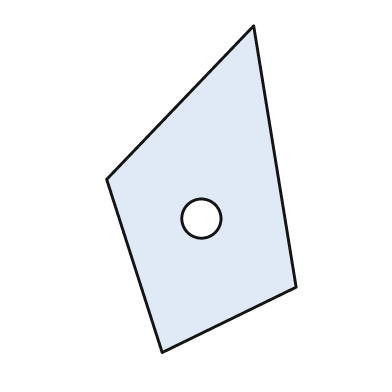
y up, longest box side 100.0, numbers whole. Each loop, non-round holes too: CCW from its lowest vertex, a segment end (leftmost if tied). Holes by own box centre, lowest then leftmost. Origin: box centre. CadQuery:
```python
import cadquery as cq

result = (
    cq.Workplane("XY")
    .moveTo(-12.0, -50.0)
    .lineTo(29.0, -30.0)
    .lineTo(16.0, 50.0)
    .lineTo(-29.0, 3.0)
    .close()
    .moveTo(0.0, -9.0)
    .circle(6.0)
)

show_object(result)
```